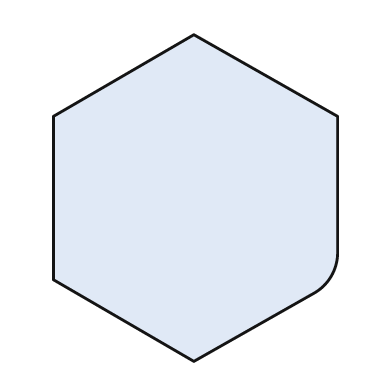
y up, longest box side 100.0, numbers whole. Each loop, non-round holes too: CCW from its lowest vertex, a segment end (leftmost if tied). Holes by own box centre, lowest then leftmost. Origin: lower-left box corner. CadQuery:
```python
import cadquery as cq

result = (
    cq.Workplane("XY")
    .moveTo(43.0, 0.0)
    .lineTo(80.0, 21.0)
    .threePointArc((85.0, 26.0), (87.0, 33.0))
    .lineTo(87.0, 75.0)
    .lineTo(43.0, 100.0)
    .lineTo(0.0, 75.0)
    .lineTo(0.0, 25.0)
    .close()
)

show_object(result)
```